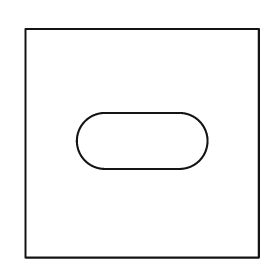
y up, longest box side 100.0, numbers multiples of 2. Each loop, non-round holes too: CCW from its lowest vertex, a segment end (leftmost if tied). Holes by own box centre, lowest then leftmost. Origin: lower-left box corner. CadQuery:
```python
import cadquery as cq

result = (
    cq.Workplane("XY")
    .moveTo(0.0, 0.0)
    .lineTo(100.0, 0.0)
    .lineTo(100.0, 98.0)
    .lineTo(0.0, 98.0)
    .close()
    .moveTo(34.0, 38.0)
    .lineTo(66.0, 38.0)
    .threePointArc((78.0, 50.0), (66.0, 62.0))
    .lineTo(34.0, 62.0)
    .threePointArc((22.0, 50.0), (34.0, 38.0))
    .close()
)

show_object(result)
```